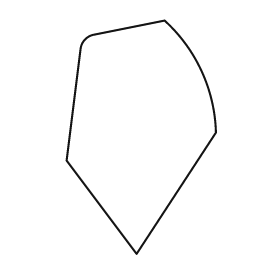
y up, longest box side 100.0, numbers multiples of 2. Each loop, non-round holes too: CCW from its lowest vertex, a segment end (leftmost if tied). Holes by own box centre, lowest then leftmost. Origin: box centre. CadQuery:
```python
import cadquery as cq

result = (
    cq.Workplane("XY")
    .moveTo(-2.0, -50.0)
    .lineTo(32.0, 2.0)
    .threePointArc((26.0, 28.0), (10.0, 50.0))
    .lineTo(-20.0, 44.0)
    .threePointArc((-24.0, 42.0), (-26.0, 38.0))
    .lineTo(-32.0, -10.0)
    .close()
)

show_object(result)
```